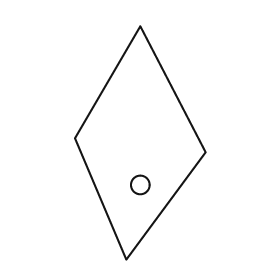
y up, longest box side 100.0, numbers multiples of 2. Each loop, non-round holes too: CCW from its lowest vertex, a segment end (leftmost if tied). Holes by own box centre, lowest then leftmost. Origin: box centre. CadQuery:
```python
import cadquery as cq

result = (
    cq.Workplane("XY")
    .moveTo(-6.0, -50.0)
    .lineTo(28.0, -4.0)
    .lineTo(0.0, 50.0)
    .lineTo(-28.0, 2.0)
    .close()
    .moveTo(0.0, -18.0)
    .circle(4.0)
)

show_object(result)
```